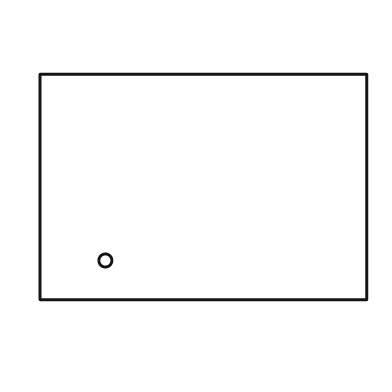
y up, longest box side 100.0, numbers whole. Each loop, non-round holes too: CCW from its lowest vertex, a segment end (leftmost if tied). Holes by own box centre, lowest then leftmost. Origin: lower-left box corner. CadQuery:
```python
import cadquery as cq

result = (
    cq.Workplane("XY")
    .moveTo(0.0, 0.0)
    .lineTo(100.0, 0.0)
    .lineTo(100.0, 69.0)
    .lineTo(0.0, 69.0)
    .close()
    .moveTo(20.0, 12.0)
    .circle(2.0)
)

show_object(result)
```